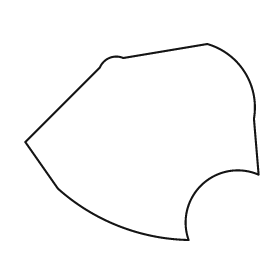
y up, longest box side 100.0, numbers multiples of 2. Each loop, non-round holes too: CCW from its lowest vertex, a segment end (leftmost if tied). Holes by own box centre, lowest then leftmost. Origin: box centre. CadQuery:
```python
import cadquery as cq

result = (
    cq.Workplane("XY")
    .moveTo(20.0, -42.0)
    .threePointArc((26.0, -18.0), (50.0, -14.0))
    .lineTo(48.0, 10.0)
    .threePointArc((44.0, 30.0), (28.0, 42.0))
    .lineTo(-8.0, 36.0)
    .threePointArc((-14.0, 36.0), (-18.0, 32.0))
    .lineTo(-50.0, 0.0)
    .lineTo(-36.0, -20.0)
    .threePointArc((-10.0, -36.0), (20.0, -42.0))
    .close()
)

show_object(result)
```